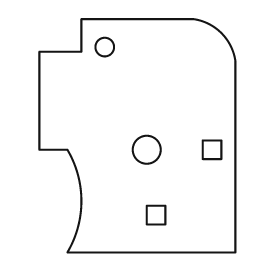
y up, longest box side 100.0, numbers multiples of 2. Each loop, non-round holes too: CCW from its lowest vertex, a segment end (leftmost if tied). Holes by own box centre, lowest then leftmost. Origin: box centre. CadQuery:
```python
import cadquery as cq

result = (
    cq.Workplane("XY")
    .moveTo(-30.0, -50.0)
    .lineTo(42.0, -50.0)
    .lineTo(42.0, 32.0)
    .threePointArc((36.0, 44.0), (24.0, 50.0))
    .lineTo(-24.0, 50.0)
    .lineTo(-24.0, 36.0)
    .lineTo(-42.0, 36.0)
    .lineTo(-42.0, -6.0)
    .lineTo(-30.0, -6.0)
    .threePointArc((-24.0, -28.0), (-30.0, -50.0))
    .close()
    .moveTo(4.0, -38.0)
    .lineTo(12.0, -38.0)
    .lineTo(12.0, -30.0)
    .lineTo(4.0, -30.0)
    .close()
    .moveTo(4.0, -6.0)
    .circle(6.0)
    .moveTo(28.0, -10.0)
    .lineTo(36.0, -10.0)
    .lineTo(36.0, -2.0)
    .lineTo(28.0, -2.0)
    .close()
    .moveTo(-14.0, 38.0)
    .circle(4.0)
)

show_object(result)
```